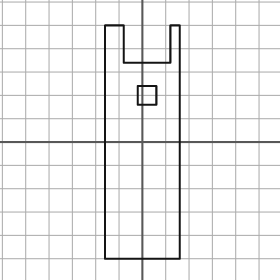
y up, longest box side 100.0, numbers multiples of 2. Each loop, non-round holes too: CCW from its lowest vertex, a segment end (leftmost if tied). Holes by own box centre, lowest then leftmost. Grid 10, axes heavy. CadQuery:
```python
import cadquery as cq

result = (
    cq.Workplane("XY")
    .moveTo(-16.0, -50.0)
    .lineTo(16.0, -50.0)
    .lineTo(16.0, 50.0)
    .lineTo(12.0, 50.0)
    .lineTo(12.0, 34.0)
    .lineTo(-8.0, 34.0)
    .lineTo(-8.0, 50.0)
    .lineTo(-16.0, 50.0)
    .close()
    .moveTo(-2.0, 16.0)
    .lineTo(6.0, 16.0)
    .lineTo(6.0, 24.0)
    .lineTo(-2.0, 24.0)
    .close()
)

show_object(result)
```